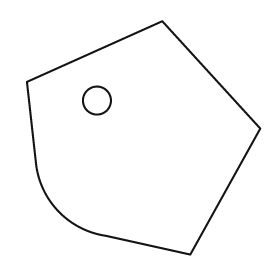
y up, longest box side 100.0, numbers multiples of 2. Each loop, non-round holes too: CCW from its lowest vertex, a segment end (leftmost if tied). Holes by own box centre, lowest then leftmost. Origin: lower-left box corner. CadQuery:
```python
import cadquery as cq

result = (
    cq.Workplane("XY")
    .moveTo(70.0, 0.0)
    .lineTo(100.0, 54.0)
    .lineTo(58.0, 100.0)
    .lineTo(0.0, 74.0)
    .lineTo(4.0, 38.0)
    .threePointArc((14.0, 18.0), (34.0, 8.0))
    .close()
    .moveTo(30.0, 66.0)
    .circle(6.0)
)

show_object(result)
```